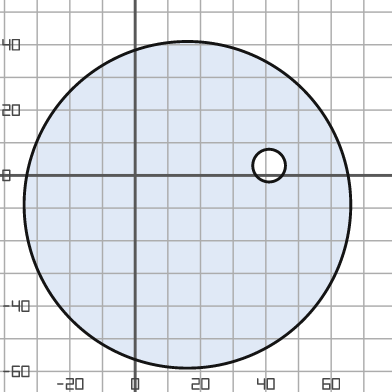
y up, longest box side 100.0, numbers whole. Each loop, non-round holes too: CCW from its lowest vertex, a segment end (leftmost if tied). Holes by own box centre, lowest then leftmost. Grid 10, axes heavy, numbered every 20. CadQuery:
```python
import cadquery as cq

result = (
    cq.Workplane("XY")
    .moveTo(16.0, -9.0)
    .circle(50.0)
    .moveTo(41.0, 3.0)
    .circle(5.0)
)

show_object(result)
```